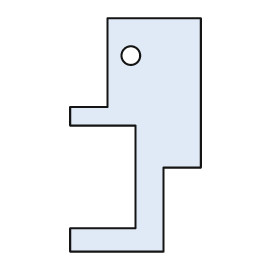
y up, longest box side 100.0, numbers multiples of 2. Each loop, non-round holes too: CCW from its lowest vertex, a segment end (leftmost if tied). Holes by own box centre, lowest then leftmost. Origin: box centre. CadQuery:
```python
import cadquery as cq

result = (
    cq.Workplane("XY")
    .moveTo(-28.0, -50.0)
    .lineTo(12.0, -50.0)
    .lineTo(12.0, -14.0)
    .lineTo(28.0, -14.0)
    .lineTo(28.0, 50.0)
    .lineTo(-12.0, 50.0)
    .lineTo(-12.0, 12.0)
    .lineTo(-28.0, 12.0)
    .lineTo(-28.0, 4.0)
    .lineTo(0.0, 4.0)
    .lineTo(0.0, -40.0)
    .lineTo(-28.0, -40.0)
    .close()
    .moveTo(-2.0, 34.0)
    .circle(4.0)
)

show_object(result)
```